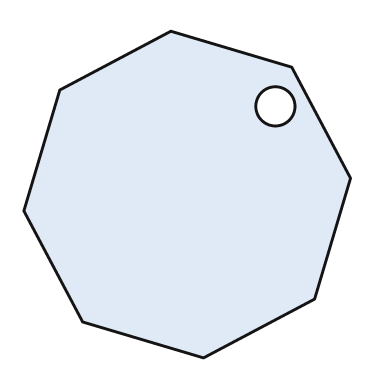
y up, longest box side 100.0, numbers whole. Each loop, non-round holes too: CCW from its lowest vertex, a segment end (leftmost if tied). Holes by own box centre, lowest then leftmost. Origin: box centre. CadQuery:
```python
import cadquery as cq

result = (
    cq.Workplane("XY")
    .moveTo(5.0, -50.0)
    .lineTo(39.0, -32.0)
    .lineTo(50.0, 5.0)
    .lineTo(32.0, 39.0)
    .lineTo(-5.0, 50.0)
    .lineTo(-39.0, 32.0)
    .lineTo(-50.0, -5.0)
    .lineTo(-32.0, -39.0)
    .close()
    .moveTo(27.0, 27.0)
    .circle(6.0)
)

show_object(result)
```